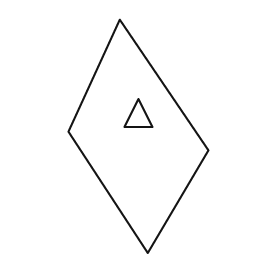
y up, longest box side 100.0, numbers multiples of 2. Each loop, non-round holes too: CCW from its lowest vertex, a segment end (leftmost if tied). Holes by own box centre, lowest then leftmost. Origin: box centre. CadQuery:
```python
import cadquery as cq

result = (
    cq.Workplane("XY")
    .moveTo(4.0, -50.0)
    .lineTo(30.0, -6.0)
    .lineTo(-8.0, 50.0)
    .lineTo(-30.0, 2.0)
    .close()
    .moveTo(-6.0, 4.0)
    .lineTo(6.0, 4.0)
    .lineTo(0.0, 16.0)
    .close()
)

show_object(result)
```